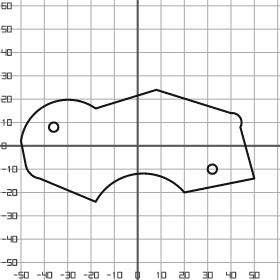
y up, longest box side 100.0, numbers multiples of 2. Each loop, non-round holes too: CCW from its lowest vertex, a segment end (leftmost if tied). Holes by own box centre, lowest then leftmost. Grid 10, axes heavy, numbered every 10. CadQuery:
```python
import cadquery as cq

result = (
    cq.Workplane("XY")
    .moveTo(-18.0, -24.0)
    .threePointArc((0.0, -12.0), (20.0, -20.0))
    .lineTo(50.0, -14.0)
    .lineTo(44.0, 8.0)
    .threePointArc((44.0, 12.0), (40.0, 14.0))
    .lineTo(8.0, 24.0)
    .lineTo(-18.0, 16.0)
    .threePointArc((-38.0, 18.0), (-50.0, 2.0))
    .lineTo(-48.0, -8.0)
    .threePointArc((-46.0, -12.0), (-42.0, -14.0))
    .close()
    .moveTo(32.0, -10.0)
    .circle(2.0)
    .moveTo(-36.0, 8.0)
    .circle(2.0)
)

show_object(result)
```